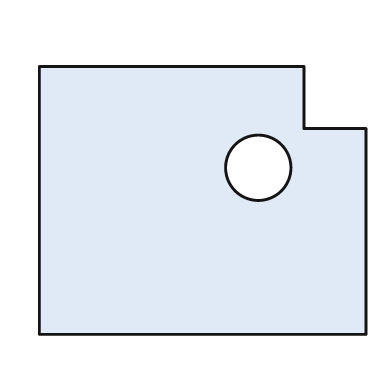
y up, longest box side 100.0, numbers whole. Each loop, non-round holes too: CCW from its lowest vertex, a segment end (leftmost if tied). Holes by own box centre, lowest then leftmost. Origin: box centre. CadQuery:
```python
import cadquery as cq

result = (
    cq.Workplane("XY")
    .moveTo(-50.0, -41.0)
    .lineTo(50.0, -41.0)
    .lineTo(50.0, 22.0)
    .lineTo(31.0, 22.0)
    .lineTo(31.0, 41.0)
    .lineTo(-50.0, 41.0)
    .close()
    .moveTo(17.0, 10.0)
    .circle(10.0)
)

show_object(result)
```